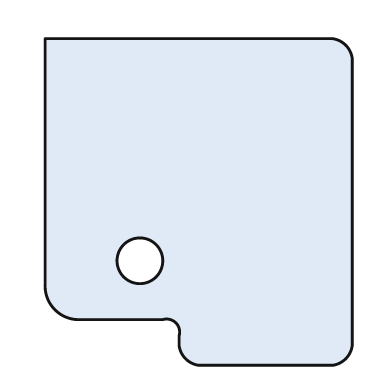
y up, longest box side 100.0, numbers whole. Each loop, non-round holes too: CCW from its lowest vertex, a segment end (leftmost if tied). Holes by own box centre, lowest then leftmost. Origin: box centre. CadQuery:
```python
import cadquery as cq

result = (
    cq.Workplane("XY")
    .moveTo(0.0, -50.0)
    .lineTo(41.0, -50.0)
    .threePointArc((45.0, -48.0), (47.0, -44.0))
    .lineTo(47.0, 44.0)
    .threePointArc((45.0, 48.0), (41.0, 50.0))
    .lineTo(-47.0, 50.0)
    .lineTo(-47.0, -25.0)
    .threePointArc((-44.0, -33.0), (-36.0, -36.0))
    .lineTo(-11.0, -36.0)
    .threePointArc((-7.0, -37.0), (-6.0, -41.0))
    .lineTo(-6.0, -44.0)
    .threePointArc((-4.0, -48.0), (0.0, -50.0))
    .close()
    .moveTo(-18.0, -18.0)
    .circle(7.0)
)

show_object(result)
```